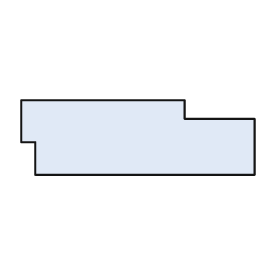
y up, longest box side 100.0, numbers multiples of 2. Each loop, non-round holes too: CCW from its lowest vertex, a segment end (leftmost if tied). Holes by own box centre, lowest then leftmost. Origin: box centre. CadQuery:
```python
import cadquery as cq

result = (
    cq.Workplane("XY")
    .moveTo(-44.0, -16.0)
    .lineTo(50.0, -16.0)
    .lineTo(50.0, 8.0)
    .lineTo(20.0, 8.0)
    .lineTo(20.0, 16.0)
    .lineTo(-50.0, 16.0)
    .lineTo(-50.0, -2.0)
    .lineTo(-44.0, -2.0)
    .close()
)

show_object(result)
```